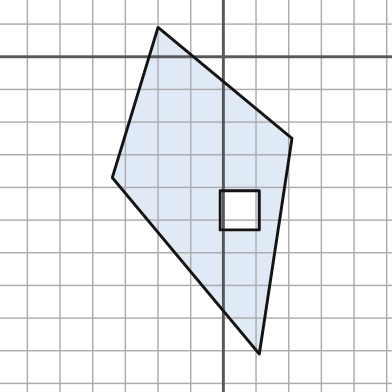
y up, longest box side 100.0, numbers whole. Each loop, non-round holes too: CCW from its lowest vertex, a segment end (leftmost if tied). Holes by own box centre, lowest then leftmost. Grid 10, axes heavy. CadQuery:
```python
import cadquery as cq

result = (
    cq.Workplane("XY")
    .moveTo(11.0, -91.0)
    .lineTo(21.0, -25.0)
    .lineTo(-20.0, 9.0)
    .lineTo(-34.0, -37.0)
    .close()
    .moveTo(-1.0, -53.0)
    .lineTo(11.0, -53.0)
    .lineTo(11.0, -41.0)
    .lineTo(-1.0, -41.0)
    .close()
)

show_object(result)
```